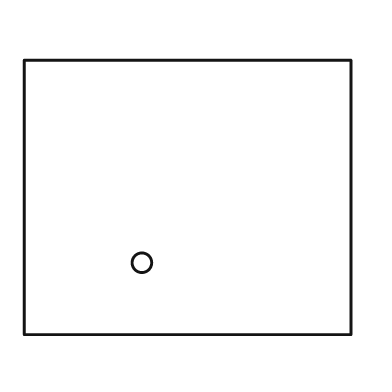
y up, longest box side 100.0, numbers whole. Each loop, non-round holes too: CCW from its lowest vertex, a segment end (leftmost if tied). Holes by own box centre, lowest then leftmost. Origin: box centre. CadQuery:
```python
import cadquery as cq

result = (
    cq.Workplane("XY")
    .moveTo(-50.0, -42.0)
    .lineTo(50.0, -42.0)
    .lineTo(50.0, 42.0)
    .lineTo(-50.0, 42.0)
    .close()
    .moveTo(-14.0, -20.0)
    .circle(3.0)
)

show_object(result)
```